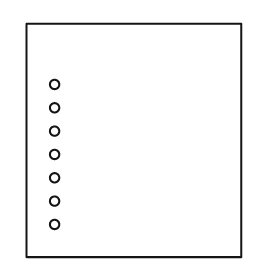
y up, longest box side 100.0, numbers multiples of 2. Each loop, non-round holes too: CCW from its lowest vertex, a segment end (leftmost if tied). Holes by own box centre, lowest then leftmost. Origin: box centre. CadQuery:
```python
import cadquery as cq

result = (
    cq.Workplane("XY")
    .moveTo(-46.0, -50.0)
    .lineTo(46.0, -50.0)
    .lineTo(46.0, 50.0)
    .lineTo(-46.0, 50.0)
    .close()
    .moveTo(-34.0, -36.0)
    .circle(2.0)
    .moveTo(-34.0, -26.0)
    .circle(2.0)
    .moveTo(-34.0, -16.0)
    .circle(2.0)
    .moveTo(-34.0, -6.0)
    .circle(2.0)
    .moveTo(-34.0, 4.0)
    .circle(2.0)
    .moveTo(-34.0, 14.0)
    .circle(2.0)
    .moveTo(-34.0, 24.0)
    .circle(2.0)
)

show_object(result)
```